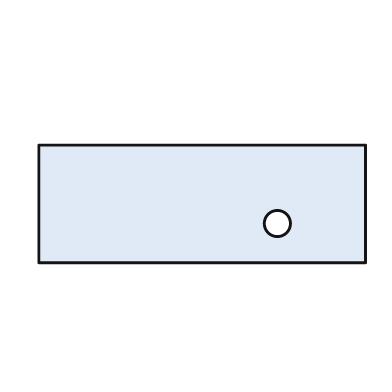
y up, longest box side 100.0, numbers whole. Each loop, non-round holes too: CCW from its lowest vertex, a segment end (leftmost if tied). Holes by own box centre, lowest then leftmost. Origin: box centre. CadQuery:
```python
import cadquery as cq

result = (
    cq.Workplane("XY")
    .moveTo(-50.0, -18.0)
    .lineTo(50.0, -18.0)
    .lineTo(50.0, 18.0)
    .lineTo(-50.0, 18.0)
    .close()
    .moveTo(23.0, -6.0)
    .circle(4.0)
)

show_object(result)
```